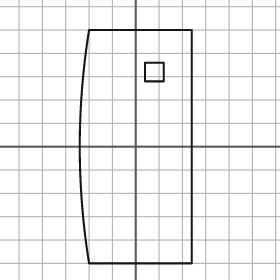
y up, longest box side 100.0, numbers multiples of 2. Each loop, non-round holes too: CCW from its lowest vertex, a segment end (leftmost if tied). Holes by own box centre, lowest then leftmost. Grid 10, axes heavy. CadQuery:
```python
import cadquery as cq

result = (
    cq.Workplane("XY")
    .moveTo(-20.0, -50.0)
    .lineTo(24.0, -50.0)
    .lineTo(24.0, 50.0)
    .lineTo(-20.0, 50.0)
    .threePointArc((-24.0, 0.0), (-20.0, -50.0))
    .close()
    .moveTo(4.0, 28.0)
    .lineTo(12.0, 28.0)
    .lineTo(12.0, 36.0)
    .lineTo(4.0, 36.0)
    .close()
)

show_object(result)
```